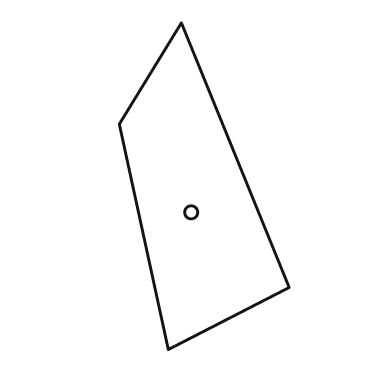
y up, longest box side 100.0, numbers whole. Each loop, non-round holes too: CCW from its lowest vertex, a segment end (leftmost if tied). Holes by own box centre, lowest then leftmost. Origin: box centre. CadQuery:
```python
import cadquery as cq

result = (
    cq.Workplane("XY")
    .moveTo(-11.0, -50.0)
    .lineTo(26.0, -31.0)
    .lineTo(-7.0, 50.0)
    .lineTo(-26.0, 19.0)
    .close()
    .moveTo(-4.0, -8.0)
    .circle(2.0)
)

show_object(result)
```